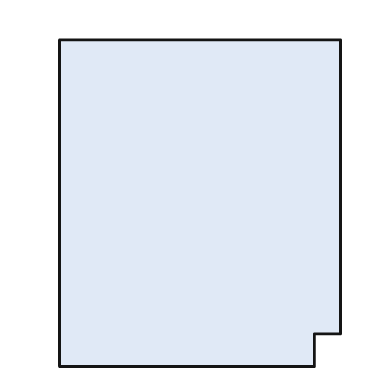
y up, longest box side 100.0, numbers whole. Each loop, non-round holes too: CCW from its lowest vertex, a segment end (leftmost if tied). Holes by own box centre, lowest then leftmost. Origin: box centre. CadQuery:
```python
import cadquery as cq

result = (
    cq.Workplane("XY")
    .moveTo(-43.0, -50.0)
    .lineTo(35.0, -50.0)
    .lineTo(35.0, -40.0)
    .lineTo(43.0, -40.0)
    .lineTo(43.0, 50.0)
    .lineTo(-43.0, 50.0)
    .close()
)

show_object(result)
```